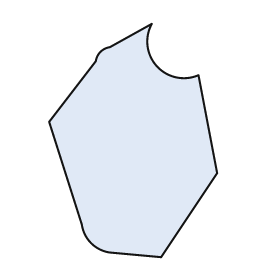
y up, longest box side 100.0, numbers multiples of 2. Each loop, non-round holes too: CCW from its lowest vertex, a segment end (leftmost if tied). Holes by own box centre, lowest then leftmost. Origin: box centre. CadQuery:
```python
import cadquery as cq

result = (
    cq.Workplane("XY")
    .moveTo(12.0, -50.0)
    .lineTo(36.0, -14.0)
    .lineTo(28.0, 28.0)
    .threePointArc((10.0, 32.0), (8.0, 50.0))
    .lineTo(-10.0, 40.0)
    .threePointArc((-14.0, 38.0), (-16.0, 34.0))
    .lineTo(-36.0, 8.0)
    .lineTo(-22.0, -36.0)
    .threePointArc((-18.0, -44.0), (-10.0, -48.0))
    .close()
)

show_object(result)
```